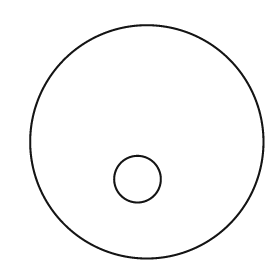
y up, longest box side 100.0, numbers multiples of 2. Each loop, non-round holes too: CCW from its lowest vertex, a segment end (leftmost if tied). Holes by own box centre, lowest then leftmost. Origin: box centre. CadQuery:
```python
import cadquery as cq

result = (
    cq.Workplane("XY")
    .moveTo(0.0, 0.0)
    .circle(50.0)
    .moveTo(-4.0, -16.0)
    .circle(10.0)
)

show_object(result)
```